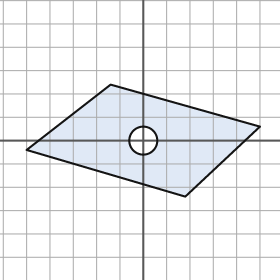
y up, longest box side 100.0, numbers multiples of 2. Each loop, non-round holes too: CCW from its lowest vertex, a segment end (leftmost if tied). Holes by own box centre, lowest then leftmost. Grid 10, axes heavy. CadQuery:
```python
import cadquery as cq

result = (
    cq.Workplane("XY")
    .moveTo(18.0, -24.0)
    .lineTo(50.0, 6.0)
    .lineTo(-14.0, 24.0)
    .lineTo(-50.0, -4.0)
    .close()
    .moveTo(0.0, 0.0)
    .circle(6.0)
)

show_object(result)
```